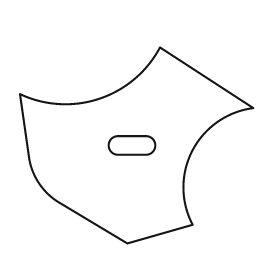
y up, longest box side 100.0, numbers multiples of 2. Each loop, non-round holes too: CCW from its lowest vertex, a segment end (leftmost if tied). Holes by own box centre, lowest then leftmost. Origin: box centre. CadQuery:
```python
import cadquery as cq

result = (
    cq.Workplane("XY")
    .moveTo(-4.0, -42.0)
    .lineTo(24.0, -34.0)
    .threePointArc((24.0, -2.0), (50.0, 16.0))
    .lineTo(10.0, 42.0)
    .threePointArc((-16.0, 20.0), (-50.0, 22.0))
    .lineTo(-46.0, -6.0)
    .threePointArc((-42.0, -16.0), (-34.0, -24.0))
    .close()
    .moveTo(-8.0, -4.0)
    .lineTo(4.0, -4.0)
    .threePointArc((8.0, 0.0), (4.0, 4.0))
    .lineTo(-8.0, 4.0)
    .threePointArc((-12.0, 0.0), (-8.0, -4.0))
    .close()
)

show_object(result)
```